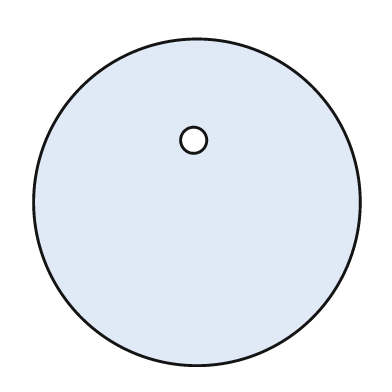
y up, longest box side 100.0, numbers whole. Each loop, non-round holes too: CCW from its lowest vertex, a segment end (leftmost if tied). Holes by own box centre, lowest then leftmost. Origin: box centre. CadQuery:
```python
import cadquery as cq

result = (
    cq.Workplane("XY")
    .moveTo(0.0, 0.0)
    .circle(50.0)
    .moveTo(-1.0, 19.0)
    .circle(4.0)
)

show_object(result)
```